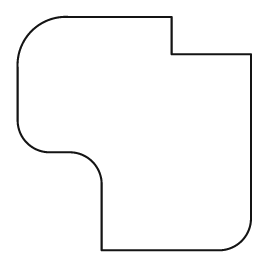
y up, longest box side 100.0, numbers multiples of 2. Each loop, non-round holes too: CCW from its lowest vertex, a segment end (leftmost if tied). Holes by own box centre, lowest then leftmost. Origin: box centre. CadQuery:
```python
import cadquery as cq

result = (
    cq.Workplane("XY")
    .moveTo(-14.0, -50.0)
    .lineTo(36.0, -50.0)
    .threePointArc((46.0, -46.0), (50.0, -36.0))
    .lineTo(50.0, 34.0)
    .lineTo(16.0, 34.0)
    .lineTo(16.0, 50.0)
    .lineTo(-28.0, 50.0)
    .threePointArc((-44.0, 44.0), (-50.0, 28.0))
    .lineTo(-50.0, 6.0)
    .threePointArc((-46.0, -4.0), (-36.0, -8.0))
    .lineTo(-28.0, -8.0)
    .threePointArc((-18.0, -12.0), (-14.0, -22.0))
    .close()
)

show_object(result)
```